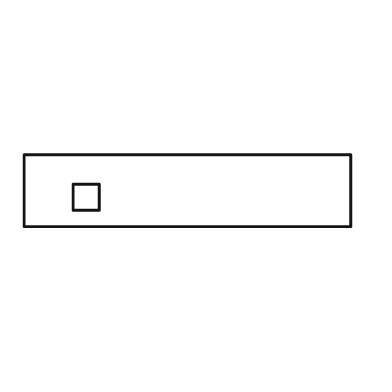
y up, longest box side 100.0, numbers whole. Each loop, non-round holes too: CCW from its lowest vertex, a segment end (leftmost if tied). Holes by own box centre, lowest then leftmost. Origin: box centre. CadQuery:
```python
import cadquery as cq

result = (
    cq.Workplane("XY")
    .moveTo(-50.0, -11.0)
    .lineTo(50.0, -11.0)
    .lineTo(50.0, 11.0)
    .lineTo(-50.0, 11.0)
    .close()
    .moveTo(-35.0, -6.0)
    .lineTo(-27.0, -6.0)
    .lineTo(-27.0, 2.0)
    .lineTo(-35.0, 2.0)
    .close()
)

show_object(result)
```